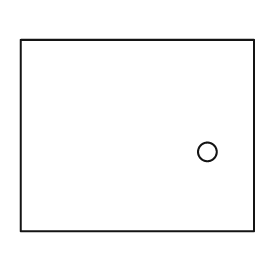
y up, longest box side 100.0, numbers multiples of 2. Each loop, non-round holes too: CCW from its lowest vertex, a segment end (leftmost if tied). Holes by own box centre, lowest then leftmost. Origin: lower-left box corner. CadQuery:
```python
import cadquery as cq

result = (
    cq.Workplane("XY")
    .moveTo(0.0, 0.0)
    .lineTo(100.0, 0.0)
    .lineTo(100.0, 82.0)
    .lineTo(0.0, 82.0)
    .close()
    .moveTo(80.0, 34.0)
    .circle(4.0)
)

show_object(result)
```